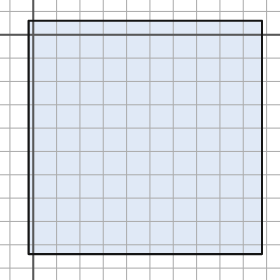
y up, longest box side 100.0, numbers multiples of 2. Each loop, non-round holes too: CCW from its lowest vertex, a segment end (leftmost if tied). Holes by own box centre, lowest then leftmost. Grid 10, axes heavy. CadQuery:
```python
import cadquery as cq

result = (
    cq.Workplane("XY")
    .moveTo(-2.0, -94.0)
    .lineTo(98.0, -94.0)
    .lineTo(98.0, 6.0)
    .lineTo(-2.0, 6.0)
    .close()
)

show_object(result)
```